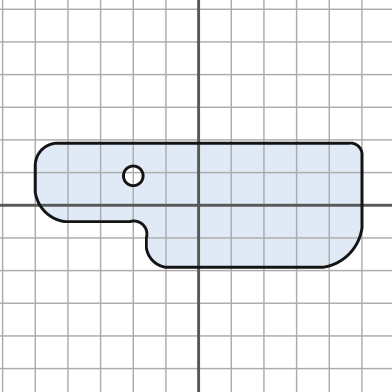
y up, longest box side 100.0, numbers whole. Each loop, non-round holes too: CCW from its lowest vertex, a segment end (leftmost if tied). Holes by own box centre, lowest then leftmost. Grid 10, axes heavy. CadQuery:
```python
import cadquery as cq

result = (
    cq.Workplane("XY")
    .moveTo(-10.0, -19.0)
    .lineTo(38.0, -19.0)
    .threePointArc((46.0, -15.0), (50.0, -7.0))
    .lineTo(50.0, 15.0)
    .threePointArc((49.0, 18.0), (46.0, 19.0))
    .lineTo(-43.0, 19.0)
    .threePointArc((-48.0, 17.0), (-50.0, 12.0))
    .lineTo(-50.0, 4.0)
    .threePointArc((-47.0, -2.0), (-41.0, -5.0))
    .lineTo(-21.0, -5.0)
    .threePointArc((-17.0, -6.0), (-16.0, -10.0))
    .lineTo(-16.0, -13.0)
    .threePointArc((-14.0, -17.0), (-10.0, -19.0))
    .close()
    .moveTo(-20.0, 9.0)
    .circle(3.0)
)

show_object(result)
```